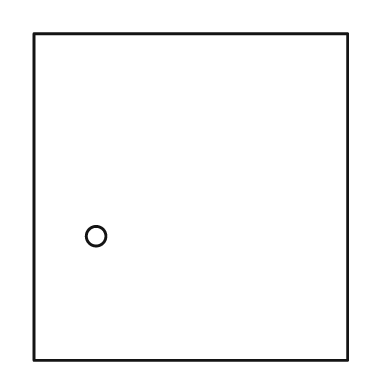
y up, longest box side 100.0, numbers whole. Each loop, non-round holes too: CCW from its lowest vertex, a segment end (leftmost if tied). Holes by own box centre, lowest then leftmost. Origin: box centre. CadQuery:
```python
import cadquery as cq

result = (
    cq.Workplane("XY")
    .moveTo(-48.0, -50.0)
    .lineTo(48.0, -50.0)
    .lineTo(48.0, 50.0)
    .lineTo(-48.0, 50.0)
    .close()
    .moveTo(-29.0, -12.0)
    .circle(3.0)
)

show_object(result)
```